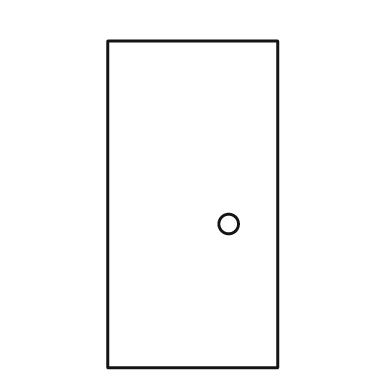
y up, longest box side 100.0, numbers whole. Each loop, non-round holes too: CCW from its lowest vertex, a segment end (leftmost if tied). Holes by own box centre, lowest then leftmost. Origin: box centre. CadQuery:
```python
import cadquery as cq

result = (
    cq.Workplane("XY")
    .moveTo(-26.0, -50.0)
    .lineTo(26.0, -50.0)
    .lineTo(26.0, 50.0)
    .lineTo(-26.0, 50.0)
    .close()
    .moveTo(11.0, -6.0)
    .circle(3.0)
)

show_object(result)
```